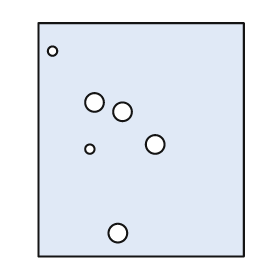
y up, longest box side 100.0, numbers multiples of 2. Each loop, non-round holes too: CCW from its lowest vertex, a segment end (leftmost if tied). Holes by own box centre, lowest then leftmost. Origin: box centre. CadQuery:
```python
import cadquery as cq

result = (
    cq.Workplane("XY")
    .moveTo(-44.0, -50.0)
    .lineTo(44.0, -50.0)
    .lineTo(44.0, 50.0)
    .lineTo(-44.0, 50.0)
    .close()
    .moveTo(-10.0, -40.0)
    .circle(4.0)
    .moveTo(-22.0, -4.0)
    .circle(2.0)
    .moveTo(6.0, -2.0)
    .circle(4.0)
    .moveTo(-8.0, 12.0)
    .circle(4.0)
    .moveTo(-20.0, 16.0)
    .circle(4.0)
    .moveTo(-38.0, 38.0)
    .circle(2.0)
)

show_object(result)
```